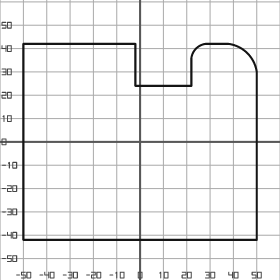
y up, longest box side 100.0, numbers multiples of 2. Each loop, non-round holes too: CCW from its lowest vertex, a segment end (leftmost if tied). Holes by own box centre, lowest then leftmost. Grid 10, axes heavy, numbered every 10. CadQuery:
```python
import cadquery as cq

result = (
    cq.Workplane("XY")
    .moveTo(-50.0, -42.0)
    .lineTo(50.0, -42.0)
    .lineTo(50.0, 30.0)
    .threePointArc((46.0, 38.0), (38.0, 42.0))
    .lineTo(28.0, 42.0)
    .threePointArc((24.0, 40.0), (22.0, 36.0))
    .lineTo(22.0, 24.0)
    .lineTo(-2.0, 24.0)
    .lineTo(-2.0, 42.0)
    .lineTo(-50.0, 42.0)
    .close()
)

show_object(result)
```